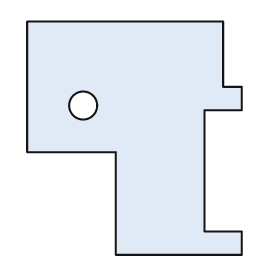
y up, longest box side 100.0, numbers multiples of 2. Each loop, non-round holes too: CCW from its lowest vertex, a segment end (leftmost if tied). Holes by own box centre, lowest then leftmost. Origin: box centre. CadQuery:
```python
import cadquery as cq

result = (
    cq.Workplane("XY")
    .moveTo(-8.0, -50.0)
    .lineTo(46.0, -50.0)
    .lineTo(46.0, -40.0)
    .lineTo(30.0, -40.0)
    .lineTo(30.0, 12.0)
    .lineTo(46.0, 12.0)
    .lineTo(46.0, 22.0)
    .lineTo(38.0, 22.0)
    .lineTo(38.0, 50.0)
    .lineTo(-46.0, 50.0)
    .lineTo(-46.0, -6.0)
    .lineTo(-8.0, -6.0)
    .close()
    .moveTo(-22.0, 14.0)
    .circle(6.0)
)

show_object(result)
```